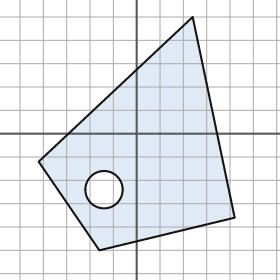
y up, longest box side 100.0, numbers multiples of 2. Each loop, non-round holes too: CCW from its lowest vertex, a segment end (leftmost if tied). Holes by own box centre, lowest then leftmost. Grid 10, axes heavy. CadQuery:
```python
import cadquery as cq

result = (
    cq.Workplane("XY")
    .moveTo(-16.0, -50.0)
    .lineTo(42.0, -36.0)
    .lineTo(24.0, 50.0)
    .lineTo(-42.0, -12.0)
    .close()
    .moveTo(-14.0, -24.0)
    .circle(8.0)
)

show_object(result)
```